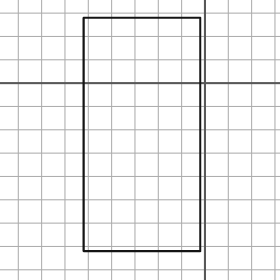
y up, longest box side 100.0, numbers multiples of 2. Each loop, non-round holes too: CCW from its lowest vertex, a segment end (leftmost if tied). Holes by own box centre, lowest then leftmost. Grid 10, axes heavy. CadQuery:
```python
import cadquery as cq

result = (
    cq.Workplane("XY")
    .moveTo(-52.0, -72.0)
    .lineTo(-2.0, -72.0)
    .lineTo(-2.0, 28.0)
    .lineTo(-52.0, 28.0)
    .close()
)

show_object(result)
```